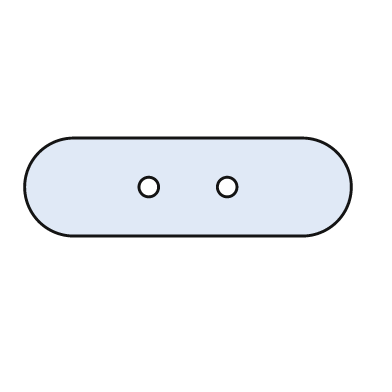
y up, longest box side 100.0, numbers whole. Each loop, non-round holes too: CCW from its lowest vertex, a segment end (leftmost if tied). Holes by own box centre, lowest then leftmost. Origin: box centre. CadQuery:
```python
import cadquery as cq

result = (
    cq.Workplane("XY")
    .moveTo(-35.0, -15.0)
    .lineTo(35.0, -15.0)
    .threePointArc((50.0, 0.0), (35.0, 15.0))
    .lineTo(-35.0, 15.0)
    .threePointArc((-50.0, 0.0), (-35.0, -15.0))
    .close()
    .moveTo(-12.0, 0.0)
    .circle(3.0)
    .moveTo(12.0, 0.0)
    .circle(3.0)
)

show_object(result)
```